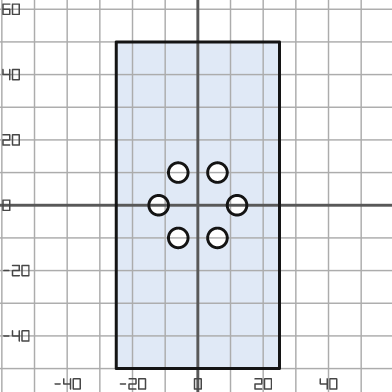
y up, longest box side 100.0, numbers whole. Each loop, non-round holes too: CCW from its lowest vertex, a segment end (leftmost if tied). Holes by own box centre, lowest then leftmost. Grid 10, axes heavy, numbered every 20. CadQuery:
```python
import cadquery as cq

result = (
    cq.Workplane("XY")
    .moveTo(-25.0, -50.0)
    .lineTo(25.0, -50.0)
    .lineTo(25.0, 50.0)
    .lineTo(-25.0, 50.0)
    .close()
    .moveTo(-6.0, -10.0)
    .circle(3.0)
    .moveTo(6.0, -10.0)
    .circle(3.0)
    .moveTo(-12.0, 0.0)
    .circle(3.0)
    .moveTo(12.0, 0.0)
    .circle(3.0)
    .moveTo(-6.0, 10.0)
    .circle(3.0)
    .moveTo(6.0, 10.0)
    .circle(3.0)
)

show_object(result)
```